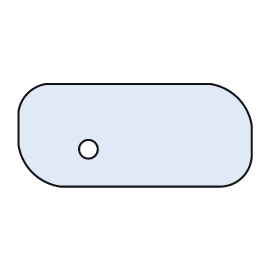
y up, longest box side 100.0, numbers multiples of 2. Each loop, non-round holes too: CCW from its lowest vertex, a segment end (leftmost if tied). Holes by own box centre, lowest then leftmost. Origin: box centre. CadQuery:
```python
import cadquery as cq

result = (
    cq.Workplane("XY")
    .moveTo(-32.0, -22.0)
    .lineTo(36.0, -22.0)
    .threePointArc((46.0, -18.0), (50.0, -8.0))
    .lineTo(50.0, 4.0)
    .threePointArc((44.0, 16.0), (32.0, 22.0))
    .lineTo(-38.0, 22.0)
    .threePointArc((-46.0, 18.0), (-50.0, 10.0))
    .lineTo(-50.0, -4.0)
    .threePointArc((-44.0, -16.0), (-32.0, -22.0))
    .close()
    .moveTo(-20.0, -6.0)
    .circle(4.0)
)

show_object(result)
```